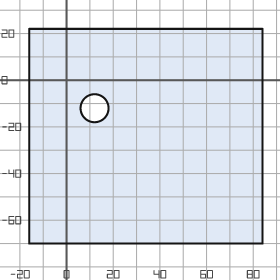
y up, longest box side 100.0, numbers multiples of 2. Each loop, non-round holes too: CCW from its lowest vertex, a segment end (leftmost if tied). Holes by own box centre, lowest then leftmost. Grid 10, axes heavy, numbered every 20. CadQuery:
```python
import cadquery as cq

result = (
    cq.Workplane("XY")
    .moveTo(-16.0, -70.0)
    .lineTo(84.0, -70.0)
    .lineTo(84.0, 22.0)
    .lineTo(-16.0, 22.0)
    .close()
    .moveTo(12.0, -12.0)
    .circle(6.0)
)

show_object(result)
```